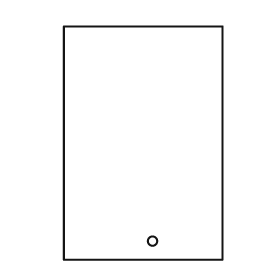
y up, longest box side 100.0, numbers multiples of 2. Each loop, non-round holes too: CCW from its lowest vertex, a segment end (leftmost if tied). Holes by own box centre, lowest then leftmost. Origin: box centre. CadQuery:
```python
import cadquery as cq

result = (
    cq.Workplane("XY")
    .moveTo(-34.0, -50.0)
    .lineTo(34.0, -50.0)
    .lineTo(34.0, 50.0)
    .lineTo(-34.0, 50.0)
    .close()
    .moveTo(4.0, -42.0)
    .circle(2.0)
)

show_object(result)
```